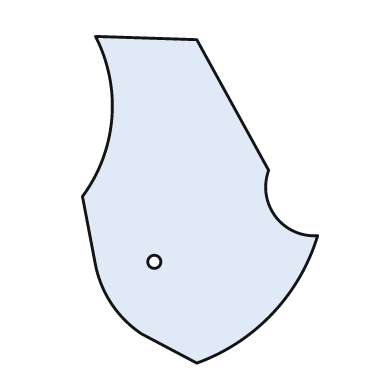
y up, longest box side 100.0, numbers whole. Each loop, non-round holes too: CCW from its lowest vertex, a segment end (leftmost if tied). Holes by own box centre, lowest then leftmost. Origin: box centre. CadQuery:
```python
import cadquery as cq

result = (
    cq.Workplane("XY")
    .moveTo(-1.0, -50.0)
    .threePointArc((22.0, -35.0), (36.0, -11.0))
    .threePointArc((23.0, -5.0), (21.0, 9.0))
    .lineTo(-1.0, 49.0)
    .lineTo(-32.0, 50.0)
    .threePointArc((-27.0, 25.0), (-36.0, 1.0))
    .lineTo(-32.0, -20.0)
    .threePointArc((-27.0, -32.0), (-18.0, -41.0))
    .close()
    .moveTo(-14.0, -19.0)
    .circle(2.0)
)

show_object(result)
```